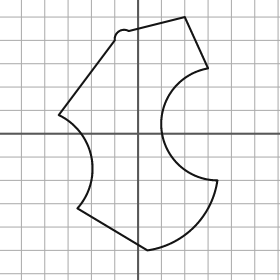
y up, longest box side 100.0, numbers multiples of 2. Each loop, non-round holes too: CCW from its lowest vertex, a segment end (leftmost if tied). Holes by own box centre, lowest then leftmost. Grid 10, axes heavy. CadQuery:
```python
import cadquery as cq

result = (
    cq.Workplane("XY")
    .moveTo(4.0, -50.0)
    .threePointArc((24.0, -40.0), (34.0, -20.0))
    .threePointArc((10.0, 2.0), (30.0, 28.0))
    .lineTo(20.0, 50.0)
    .lineTo(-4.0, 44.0)
    .threePointArc((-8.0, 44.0), (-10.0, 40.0))
    .lineTo(-34.0, 8.0)
    .threePointArc((-20.0, -10.0), (-26.0, -32.0))
    .close()
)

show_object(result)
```